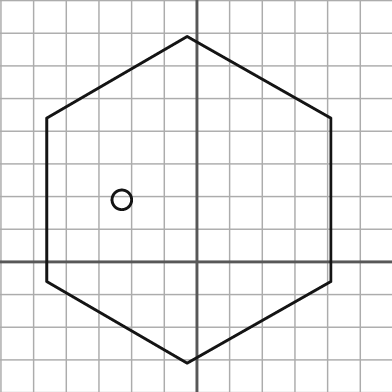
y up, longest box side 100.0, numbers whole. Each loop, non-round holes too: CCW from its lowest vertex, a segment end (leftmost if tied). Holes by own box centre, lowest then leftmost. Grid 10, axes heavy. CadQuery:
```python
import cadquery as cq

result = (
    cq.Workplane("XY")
    .moveTo(-3.0, -31.0)
    .lineTo(41.0, -6.0)
    .lineTo(41.0, 44.0)
    .lineTo(-3.0, 69.0)
    .lineTo(-46.0, 44.0)
    .lineTo(-46.0, -6.0)
    .close()
    .moveTo(-23.0, 19.0)
    .circle(3.0)
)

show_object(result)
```